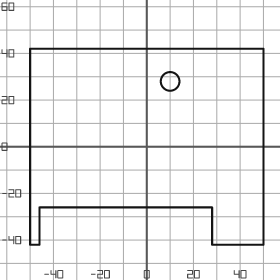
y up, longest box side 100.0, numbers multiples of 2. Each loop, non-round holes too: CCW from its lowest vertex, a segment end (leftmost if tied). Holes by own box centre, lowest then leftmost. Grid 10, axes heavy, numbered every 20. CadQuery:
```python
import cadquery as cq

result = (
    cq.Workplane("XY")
    .moveTo(-50.0, -42.0)
    .lineTo(-46.0, -42.0)
    .lineTo(-46.0, -26.0)
    .lineTo(28.0, -26.0)
    .lineTo(28.0, -42.0)
    .lineTo(50.0, -42.0)
    .lineTo(50.0, 42.0)
    .lineTo(-50.0, 42.0)
    .close()
    .moveTo(10.0, 28.0)
    .circle(4.0)
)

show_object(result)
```